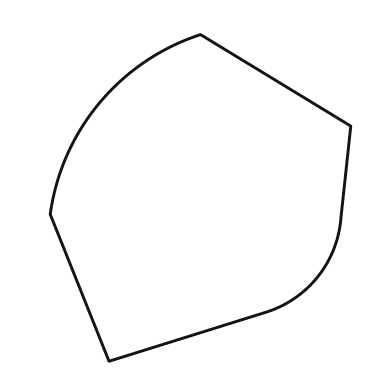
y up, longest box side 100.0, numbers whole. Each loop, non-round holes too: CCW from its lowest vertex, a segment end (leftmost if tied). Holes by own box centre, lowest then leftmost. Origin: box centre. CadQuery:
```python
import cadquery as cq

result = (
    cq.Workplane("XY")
    .moveTo(-28.0, -50.0)
    .lineTo(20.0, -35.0)
    .threePointArc((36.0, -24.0), (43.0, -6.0))
    .lineTo(46.0, 22.0)
    .lineTo(0.0, 50.0)
    .threePointArc((-31.0, 29.0), (-46.0, -5.0))
    .close()
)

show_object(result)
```